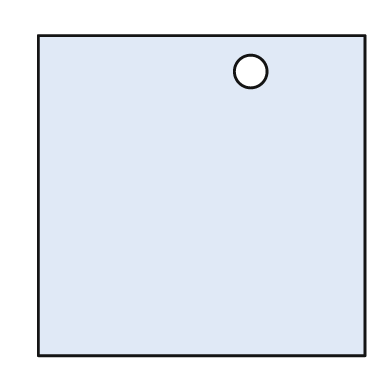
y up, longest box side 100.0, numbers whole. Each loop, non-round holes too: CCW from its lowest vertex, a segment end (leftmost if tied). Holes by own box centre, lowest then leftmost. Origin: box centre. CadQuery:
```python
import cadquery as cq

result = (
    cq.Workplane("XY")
    .moveTo(-50.0, -49.0)
    .lineTo(50.0, -49.0)
    .lineTo(50.0, 49.0)
    .lineTo(-50.0, 49.0)
    .close()
    .moveTo(15.0, 38.0)
    .circle(5.0)
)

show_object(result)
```